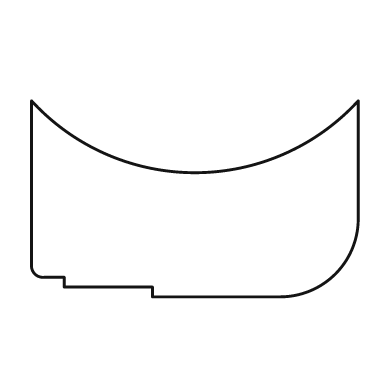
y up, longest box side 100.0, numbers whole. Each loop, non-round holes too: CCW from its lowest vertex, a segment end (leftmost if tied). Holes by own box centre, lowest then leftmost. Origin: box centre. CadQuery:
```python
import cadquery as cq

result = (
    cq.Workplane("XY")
    .moveTo(-13.0, -30.0)
    .lineTo(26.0, -30.0)
    .threePointArc((43.0, -23.0), (50.0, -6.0))
    .lineTo(50.0, 30.0)
    .threePointArc((0.0, 8.0), (-50.0, 30.0))
    .lineTo(-50.0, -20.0)
    .threePointArc((-49.0, -23.0), (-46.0, -24.0))
    .lineTo(-40.0, -24.0)
    .lineTo(-40.0, -27.0)
    .lineTo(-13.0, -27.0)
    .close()
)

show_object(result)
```